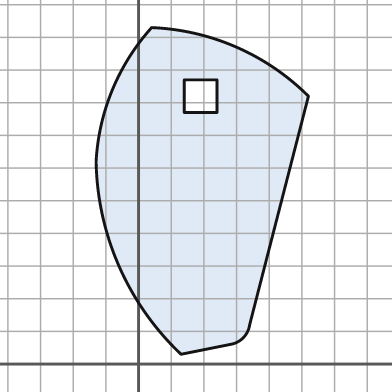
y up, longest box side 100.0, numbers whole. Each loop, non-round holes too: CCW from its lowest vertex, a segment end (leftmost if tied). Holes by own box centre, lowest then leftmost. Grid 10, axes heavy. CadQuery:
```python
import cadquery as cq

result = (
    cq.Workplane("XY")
    .moveTo(13.0, 3.0)
    .lineTo(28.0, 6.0)
    .threePointArc((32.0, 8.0), (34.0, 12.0))
    .lineTo(52.0, 82.0)
    .threePointArc((30.0, 97.0), (4.0, 103.0))
    .threePointArc((-8.0, 84.0), (-13.0, 62.0))
    .threePointArc((-6.0, 30.0), (13.0, 3.0))
    .close()
    .moveTo(14.0, 77.0)
    .lineTo(24.0, 77.0)
    .lineTo(24.0, 87.0)
    .lineTo(14.0, 87.0)
    .close()
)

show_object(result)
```